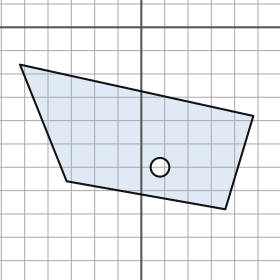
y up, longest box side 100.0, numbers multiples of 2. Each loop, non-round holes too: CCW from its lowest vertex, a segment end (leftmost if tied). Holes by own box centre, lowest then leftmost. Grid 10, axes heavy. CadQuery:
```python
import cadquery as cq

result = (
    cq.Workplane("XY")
    .moveTo(36.0, -78.0)
    .lineTo(48.0, -38.0)
    .lineTo(-52.0, -16.0)
    .lineTo(-32.0, -66.0)
    .close()
    .moveTo(8.0, -60.0)
    .circle(4.0)
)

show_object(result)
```